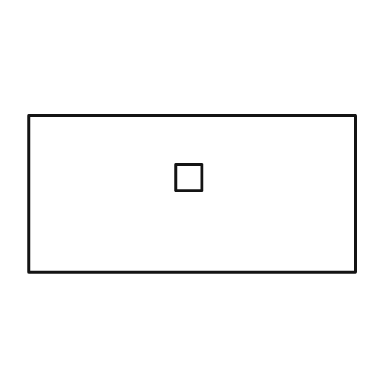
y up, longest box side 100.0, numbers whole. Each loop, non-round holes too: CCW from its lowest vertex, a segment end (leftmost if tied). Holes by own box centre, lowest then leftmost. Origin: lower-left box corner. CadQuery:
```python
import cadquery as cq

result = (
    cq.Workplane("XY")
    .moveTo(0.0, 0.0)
    .lineTo(100.0, 0.0)
    .lineTo(100.0, 48.0)
    .lineTo(0.0, 48.0)
    .close()
    .moveTo(45.0, 25.0)
    .lineTo(53.0, 25.0)
    .lineTo(53.0, 33.0)
    .lineTo(45.0, 33.0)
    .close()
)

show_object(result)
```